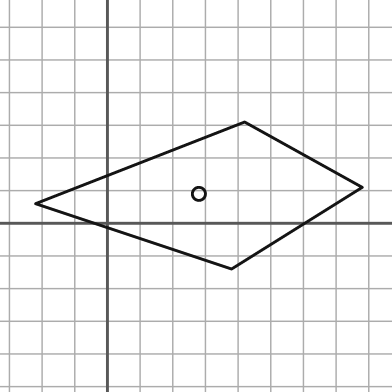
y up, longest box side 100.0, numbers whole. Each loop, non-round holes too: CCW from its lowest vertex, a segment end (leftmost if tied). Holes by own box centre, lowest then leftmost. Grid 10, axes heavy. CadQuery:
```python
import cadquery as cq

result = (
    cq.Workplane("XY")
    .moveTo(38.0, -14.0)
    .lineTo(78.0, 11.0)
    .lineTo(42.0, 31.0)
    .lineTo(-22.0, 6.0)
    .close()
    .moveTo(28.0, 9.0)
    .circle(2.0)
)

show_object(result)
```